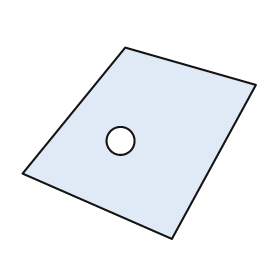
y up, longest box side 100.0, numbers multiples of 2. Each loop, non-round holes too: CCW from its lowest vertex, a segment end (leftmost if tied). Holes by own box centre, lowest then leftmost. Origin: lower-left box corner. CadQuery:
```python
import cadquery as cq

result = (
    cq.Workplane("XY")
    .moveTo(64.0, 0.0)
    .lineTo(100.0, 66.0)
    .lineTo(44.0, 82.0)
    .lineTo(0.0, 28.0)
    .close()
    .moveTo(42.0, 42.0)
    .circle(6.0)
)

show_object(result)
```